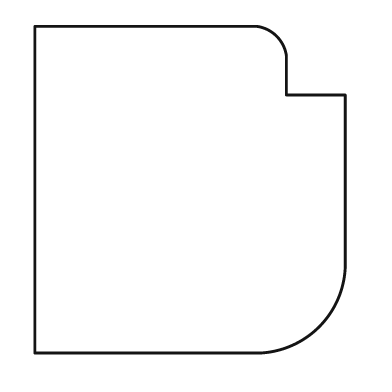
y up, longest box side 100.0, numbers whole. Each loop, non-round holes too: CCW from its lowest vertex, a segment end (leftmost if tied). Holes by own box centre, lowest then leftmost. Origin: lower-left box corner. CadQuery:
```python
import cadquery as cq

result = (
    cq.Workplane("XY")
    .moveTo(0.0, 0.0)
    .lineTo(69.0, 0.0)
    .threePointArc((87.0, 8.0), (95.0, 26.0))
    .lineTo(95.0, 79.0)
    .lineTo(77.0, 79.0)
    .lineTo(77.0, 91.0)
    .threePointArc((74.0, 97.0), (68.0, 100.0))
    .lineTo(0.0, 100.0)
    .close()
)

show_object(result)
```